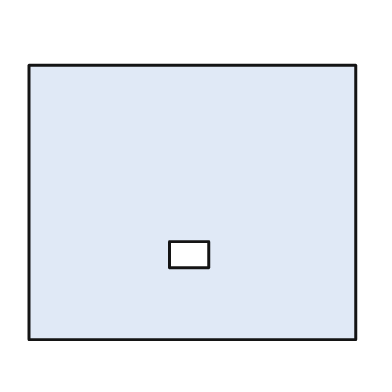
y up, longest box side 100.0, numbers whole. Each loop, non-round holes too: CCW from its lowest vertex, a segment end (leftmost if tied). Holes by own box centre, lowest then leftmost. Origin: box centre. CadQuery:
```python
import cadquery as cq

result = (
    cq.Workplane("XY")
    .moveTo(-50.0, -42.0)
    .lineTo(50.0, -42.0)
    .lineTo(50.0, 42.0)
    .lineTo(-50.0, 42.0)
    .close()
    .moveTo(-7.0, -20.0)
    .lineTo(5.0, -20.0)
    .lineTo(5.0, -12.0)
    .lineTo(-7.0, -12.0)
    .close()
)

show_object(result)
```